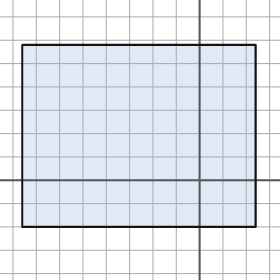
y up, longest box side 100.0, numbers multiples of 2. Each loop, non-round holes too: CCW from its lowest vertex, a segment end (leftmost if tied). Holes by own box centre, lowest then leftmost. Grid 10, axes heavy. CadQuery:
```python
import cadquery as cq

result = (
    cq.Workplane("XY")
    .moveTo(-76.0, -20.0)
    .lineTo(24.0, -20.0)
    .lineTo(24.0, 58.0)
    .lineTo(-76.0, 58.0)
    .close()
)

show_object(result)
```